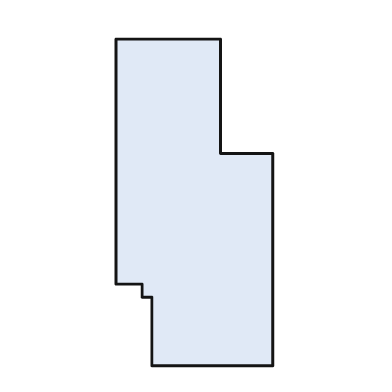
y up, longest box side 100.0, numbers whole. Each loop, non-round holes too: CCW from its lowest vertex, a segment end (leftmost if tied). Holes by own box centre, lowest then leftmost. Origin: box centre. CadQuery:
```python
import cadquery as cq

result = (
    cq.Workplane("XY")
    .moveTo(-13.0, -50.0)
    .lineTo(24.0, -50.0)
    .lineTo(24.0, 15.0)
    .lineTo(8.0, 15.0)
    .lineTo(8.0, 50.0)
    .lineTo(-24.0, 50.0)
    .lineTo(-24.0, -25.0)
    .lineTo(-16.0, -25.0)
    .lineTo(-16.0, -29.0)
    .lineTo(-13.0, -29.0)
    .close()
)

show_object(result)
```